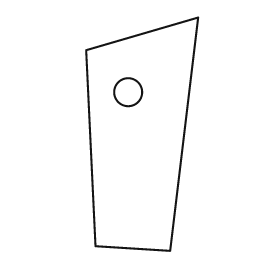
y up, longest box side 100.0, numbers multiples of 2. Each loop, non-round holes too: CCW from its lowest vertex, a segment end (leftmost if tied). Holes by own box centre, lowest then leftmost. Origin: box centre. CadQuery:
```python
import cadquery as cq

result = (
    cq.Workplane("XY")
    .moveTo(12.0, -50.0)
    .lineTo(24.0, 50.0)
    .lineTo(-24.0, 36.0)
    .lineTo(-20.0, -48.0)
    .close()
    .moveTo(-6.0, 18.0)
    .circle(6.0)
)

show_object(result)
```